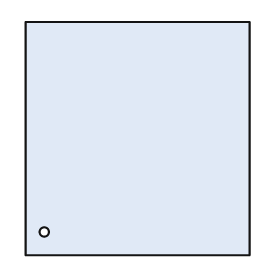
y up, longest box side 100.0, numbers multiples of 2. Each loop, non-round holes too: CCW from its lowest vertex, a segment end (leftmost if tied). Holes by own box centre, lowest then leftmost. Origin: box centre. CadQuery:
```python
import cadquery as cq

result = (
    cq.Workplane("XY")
    .moveTo(-48.0, -50.0)
    .lineTo(48.0, -50.0)
    .lineTo(48.0, 50.0)
    .lineTo(-48.0, 50.0)
    .close()
    .moveTo(-40.0, -40.0)
    .circle(2.0)
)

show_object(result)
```